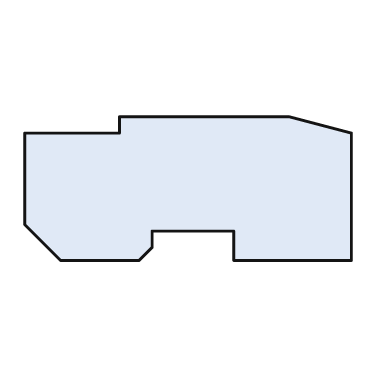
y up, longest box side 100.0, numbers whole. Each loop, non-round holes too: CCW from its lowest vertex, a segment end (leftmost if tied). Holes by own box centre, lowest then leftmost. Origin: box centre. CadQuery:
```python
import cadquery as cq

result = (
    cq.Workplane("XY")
    .moveTo(-39.0, -22.0)
    .lineTo(-15.0, -22.0)
    .lineTo(-11.0, -18.0)
    .lineTo(-11.0, -13.0)
    .lineTo(14.0, -13.0)
    .lineTo(14.0, -22.0)
    .lineTo(50.0, -22.0)
    .lineTo(50.0, 17.0)
    .lineTo(31.0, 22.0)
    .lineTo(-21.0, 22.0)
    .lineTo(-21.0, 17.0)
    .lineTo(-50.0, 17.0)
    .lineTo(-50.0, -11.0)
    .close()
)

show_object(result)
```